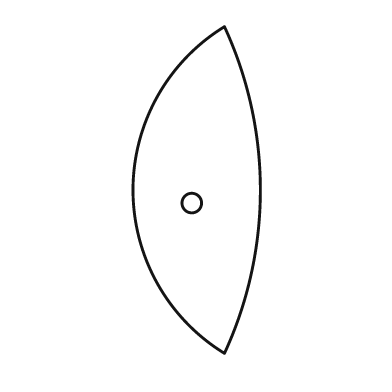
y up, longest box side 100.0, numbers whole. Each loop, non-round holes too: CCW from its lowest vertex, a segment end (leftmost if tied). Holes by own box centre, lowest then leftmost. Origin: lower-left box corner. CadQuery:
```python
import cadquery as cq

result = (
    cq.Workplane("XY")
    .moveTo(28.0, 0.0)
    .threePointArc((39.0, 50.0), (28.0, 100.0))
    .threePointArc((0.0, 50.0), (28.0, 0.0))
    .close()
    .moveTo(18.0, 46.0)
    .circle(3.0)
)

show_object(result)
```